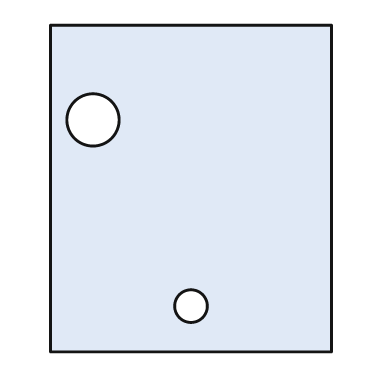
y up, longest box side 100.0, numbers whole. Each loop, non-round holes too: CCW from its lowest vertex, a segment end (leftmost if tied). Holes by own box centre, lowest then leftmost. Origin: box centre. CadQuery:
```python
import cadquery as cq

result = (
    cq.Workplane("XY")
    .moveTo(-43.0, -50.0)
    .lineTo(43.0, -50.0)
    .lineTo(43.0, 50.0)
    .lineTo(-43.0, 50.0)
    .close()
    .moveTo(0.0, -36.0)
    .circle(5.0)
    .moveTo(-30.0, 21.0)
    .circle(8.0)
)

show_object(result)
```